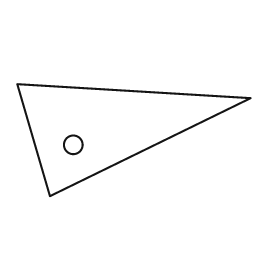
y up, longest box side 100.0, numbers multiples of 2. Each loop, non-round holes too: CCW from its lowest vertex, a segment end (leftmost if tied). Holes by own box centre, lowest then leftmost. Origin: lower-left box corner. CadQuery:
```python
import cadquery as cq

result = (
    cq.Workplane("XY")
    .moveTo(14.0, 0.0)
    .lineTo(100.0, 42.0)
    .lineTo(0.0, 48.0)
    .close()
    .moveTo(24.0, 22.0)
    .circle(4.0)
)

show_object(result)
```